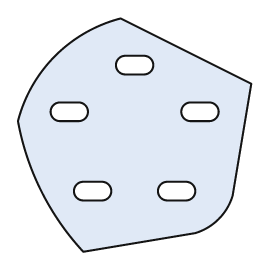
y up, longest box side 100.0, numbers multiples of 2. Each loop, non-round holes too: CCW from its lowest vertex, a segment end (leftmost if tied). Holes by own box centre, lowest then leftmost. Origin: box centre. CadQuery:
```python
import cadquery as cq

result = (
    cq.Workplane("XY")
    .moveTo(-22.0, -50.0)
    .lineTo(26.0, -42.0)
    .threePointArc((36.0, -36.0), (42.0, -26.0))
    .lineTo(50.0, 22.0)
    .lineTo(-6.0, 50.0)
    .threePointArc((-34.0, 34.0), (-50.0, 6.0))
    .threePointArc((-40.0, -24.0), (-22.0, -50.0))
    .close()
    .moveTo(-22.0, -28.0)
    .lineTo(-14.0, -28.0)
    .threePointArc((-10.0, -24.0), (-14.0, -20.0))
    .lineTo(-22.0, -20.0)
    .threePointArc((-26.0, -24.0), (-22.0, -28.0))
    .close()
    .moveTo(14.0, -28.0)
    .lineTo(22.0, -28.0)
    .threePointArc((26.0, -24.0), (22.0, -20.0))
    .lineTo(14.0, -20.0)
    .threePointArc((10.0, -24.0), (14.0, -28.0))
    .close()
    .moveTo(-32.0, 6.0)
    .lineTo(-24.0, 6.0)
    .threePointArc((-20.0, 10.0), (-24.0, 14.0))
    .lineTo(-32.0, 14.0)
    .threePointArc((-36.0, 10.0), (-32.0, 6.0))
    .close()
    .moveTo(24.0, 6.0)
    .lineTo(32.0, 6.0)
    .threePointArc((36.0, 10.0), (32.0, 14.0))
    .lineTo(24.0, 14.0)
    .threePointArc((20.0, 10.0), (24.0, 6.0))
    .close()
    .moveTo(-4.0, 26.0)
    .lineTo(4.0, 26.0)
    .threePointArc((8.0, 30.0), (4.0, 34.0))
    .lineTo(-4.0, 34.0)
    .threePointArc((-8.0, 30.0), (-4.0, 26.0))
    .close()
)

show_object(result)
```